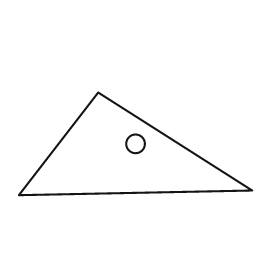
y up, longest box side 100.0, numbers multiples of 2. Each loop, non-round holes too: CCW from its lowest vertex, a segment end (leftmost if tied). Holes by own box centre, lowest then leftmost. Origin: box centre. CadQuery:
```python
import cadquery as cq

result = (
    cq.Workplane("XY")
    .moveTo(-50.0, -22.0)
    .lineTo(50.0, -20.0)
    .lineTo(-16.0, 22.0)
    .close()
    .moveTo(0.0, 0.0)
    .circle(4.0)
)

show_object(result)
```